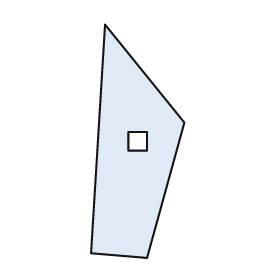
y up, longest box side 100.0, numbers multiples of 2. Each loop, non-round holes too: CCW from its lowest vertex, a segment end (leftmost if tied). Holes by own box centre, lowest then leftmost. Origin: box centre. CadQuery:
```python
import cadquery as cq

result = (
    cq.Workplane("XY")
    .moveTo(4.0, -50.0)
    .lineTo(20.0, 8.0)
    .lineTo(-14.0, 50.0)
    .lineTo(-20.0, -48.0)
    .close()
    .moveTo(-4.0, -4.0)
    .lineTo(4.0, -4.0)
    .lineTo(4.0, 4.0)
    .lineTo(-4.0, 4.0)
    .close()
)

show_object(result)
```